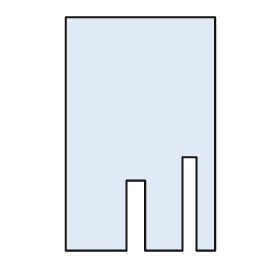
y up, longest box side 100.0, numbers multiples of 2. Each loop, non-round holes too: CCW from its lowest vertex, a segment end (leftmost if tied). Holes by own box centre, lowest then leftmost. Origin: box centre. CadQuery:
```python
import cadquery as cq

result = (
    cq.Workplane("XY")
    .moveTo(-32.0, -50.0)
    .lineTo(-6.0, -50.0)
    .lineTo(-6.0, -20.0)
    .lineTo(2.0, -20.0)
    .lineTo(2.0, -50.0)
    .lineTo(18.0, -50.0)
    .lineTo(18.0, -10.0)
    .lineTo(24.0, -10.0)
    .lineTo(24.0, -50.0)
    .lineTo(32.0, -50.0)
    .lineTo(32.0, 50.0)
    .lineTo(-32.0, 50.0)
    .close()
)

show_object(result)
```